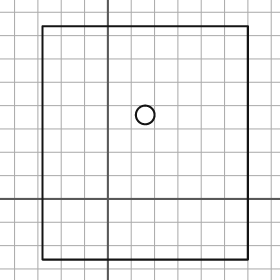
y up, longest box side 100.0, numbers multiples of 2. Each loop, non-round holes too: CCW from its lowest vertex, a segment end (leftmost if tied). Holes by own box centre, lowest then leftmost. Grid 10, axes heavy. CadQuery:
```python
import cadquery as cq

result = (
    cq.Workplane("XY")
    .moveTo(-28.0, -26.0)
    .lineTo(60.0, -26.0)
    .lineTo(60.0, 74.0)
    .lineTo(-28.0, 74.0)
    .close()
    .moveTo(16.0, 36.0)
    .circle(4.0)
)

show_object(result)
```